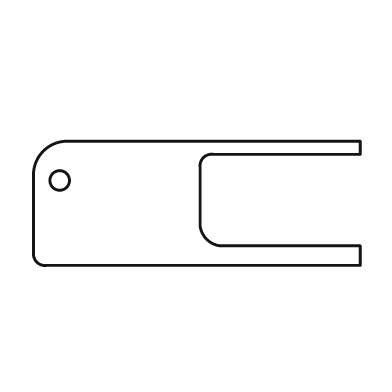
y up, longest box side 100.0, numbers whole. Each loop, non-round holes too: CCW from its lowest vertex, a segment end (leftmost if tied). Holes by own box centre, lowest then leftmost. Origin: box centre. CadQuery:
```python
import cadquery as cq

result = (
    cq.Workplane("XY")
    .moveTo(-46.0, -19.0)
    .lineTo(50.0, -19.0)
    .lineTo(50.0, -13.0)
    .lineTo(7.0, -13.0)
    .threePointArc((3.0, -11.0), (1.0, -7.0))
    .lineTo(1.0, 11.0)
    .threePointArc((2.0, 14.0), (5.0, 15.0))
    .lineTo(50.0, 15.0)
    .lineTo(50.0, 19.0)
    .lineTo(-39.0, 19.0)
    .threePointArc((-47.0, 16.0), (-50.0, 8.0))
    .lineTo(-50.0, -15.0)
    .threePointArc((-49.0, -18.0), (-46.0, -19.0))
    .close()
    .moveTo(-42.0, 7.0)
    .circle(3.0)
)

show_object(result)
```